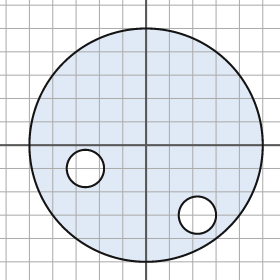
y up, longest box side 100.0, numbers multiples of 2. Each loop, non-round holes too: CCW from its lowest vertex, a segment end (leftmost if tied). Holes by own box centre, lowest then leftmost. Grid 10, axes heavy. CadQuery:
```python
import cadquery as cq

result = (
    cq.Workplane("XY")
    .moveTo(0.0, 0.0)
    .circle(50.0)
    .moveTo(22.0, -30.0)
    .circle(8.0)
    .moveTo(-26.0, -10.0)
    .circle(8.0)
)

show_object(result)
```